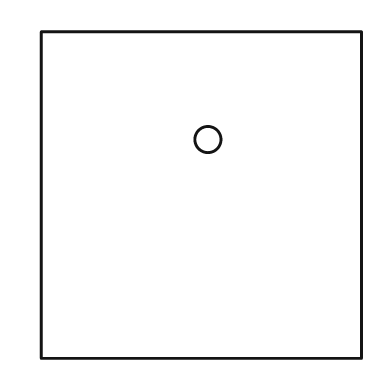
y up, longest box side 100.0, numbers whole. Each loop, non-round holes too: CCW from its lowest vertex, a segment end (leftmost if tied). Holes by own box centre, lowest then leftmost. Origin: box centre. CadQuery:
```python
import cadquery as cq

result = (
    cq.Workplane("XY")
    .moveTo(-49.0, -50.0)
    .lineTo(49.0, -50.0)
    .lineTo(49.0, 50.0)
    .lineTo(-49.0, 50.0)
    .close()
    .moveTo(2.0, 17.0)
    .circle(4.0)
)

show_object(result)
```